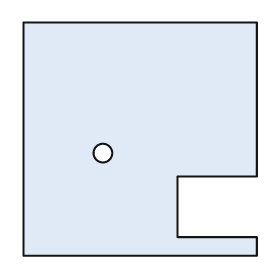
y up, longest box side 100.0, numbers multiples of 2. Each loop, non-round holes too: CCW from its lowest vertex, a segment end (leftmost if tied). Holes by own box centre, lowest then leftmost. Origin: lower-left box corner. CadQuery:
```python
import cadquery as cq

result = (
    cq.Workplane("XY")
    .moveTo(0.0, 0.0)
    .lineTo(100.0, 0.0)
    .lineTo(100.0, 8.0)
    .lineTo(66.0, 8.0)
    .lineTo(66.0, 34.0)
    .lineTo(100.0, 34.0)
    .lineTo(100.0, 100.0)
    .lineTo(0.0, 100.0)
    .close()
    .moveTo(34.0, 44.0)
    .circle(4.0)
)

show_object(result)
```